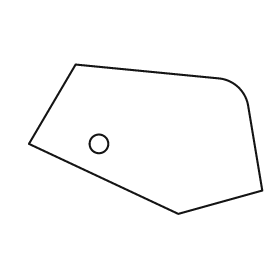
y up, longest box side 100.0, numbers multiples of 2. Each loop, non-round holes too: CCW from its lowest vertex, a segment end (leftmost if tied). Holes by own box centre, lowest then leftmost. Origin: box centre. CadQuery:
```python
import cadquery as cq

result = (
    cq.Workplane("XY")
    .moveTo(14.0, -32.0)
    .lineTo(50.0, -22.0)
    .lineTo(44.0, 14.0)
    .threePointArc((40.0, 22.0), (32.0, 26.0))
    .lineTo(-30.0, 32.0)
    .lineTo(-50.0, -2.0)
    .close()
    .moveTo(-20.0, -2.0)
    .circle(4.0)
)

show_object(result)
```